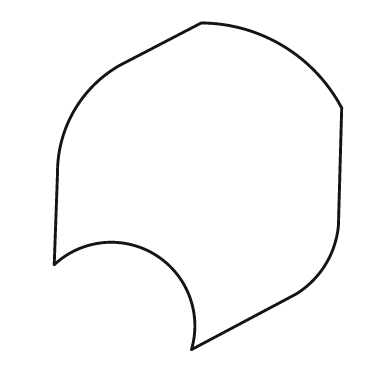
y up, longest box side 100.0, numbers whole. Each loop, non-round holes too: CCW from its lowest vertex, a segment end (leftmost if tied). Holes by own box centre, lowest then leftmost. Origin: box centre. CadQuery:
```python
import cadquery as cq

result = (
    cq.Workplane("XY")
    .moveTo(-2.0, -50.0)
    .lineTo(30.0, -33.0)
    .threePointArc((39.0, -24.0), (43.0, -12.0))
    .lineTo(44.0, 24.0)
    .threePointArc((26.0, 43.0), (1.0, 50.0))
    .lineTo(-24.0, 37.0)
    .threePointArc((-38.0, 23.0), (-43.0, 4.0))
    .lineTo(-44.0, -24.0)
    .threePointArc((-13.0, -21.0), (-2.0, -50.0))
    .close()
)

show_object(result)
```